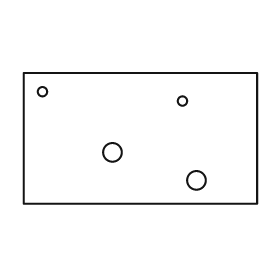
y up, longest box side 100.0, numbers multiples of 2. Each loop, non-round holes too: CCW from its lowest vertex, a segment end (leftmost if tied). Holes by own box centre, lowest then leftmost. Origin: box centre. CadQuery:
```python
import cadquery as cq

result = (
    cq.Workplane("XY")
    .moveTo(-50.0, -28.0)
    .lineTo(50.0, -28.0)
    .lineTo(50.0, 28.0)
    .lineTo(-50.0, 28.0)
    .close()
    .moveTo(24.0, -18.0)
    .circle(4.0)
    .moveTo(-12.0, -6.0)
    .circle(4.0)
    .moveTo(18.0, 16.0)
    .circle(2.0)
    .moveTo(-42.0, 20.0)
    .circle(2.0)
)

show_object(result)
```